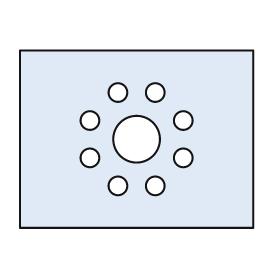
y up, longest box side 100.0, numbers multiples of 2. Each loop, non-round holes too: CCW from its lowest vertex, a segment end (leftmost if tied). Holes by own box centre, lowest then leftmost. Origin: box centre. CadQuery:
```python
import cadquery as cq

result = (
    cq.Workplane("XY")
    .moveTo(-50.0, -38.0)
    .lineTo(50.0, -38.0)
    .lineTo(50.0, 38.0)
    .lineTo(-50.0, 38.0)
    .close()
    .moveTo(-8.0, -20.0)
    .circle(4.0)
    .moveTo(8.0, -20.0)
    .circle(4.0)
    .moveTo(-20.0, -8.0)
    .circle(4.0)
    .moveTo(20.0, -8.0)
    .circle(4.0)
    .moveTo(0.0, 0.0)
    .circle(10.0)
    .moveTo(-20.0, 8.0)
    .circle(4.0)
    .moveTo(20.0, 8.0)
    .circle(4.0)
    .moveTo(-8.0, 20.0)
    .circle(4.0)
    .moveTo(8.0, 20.0)
    .circle(4.0)
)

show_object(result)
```